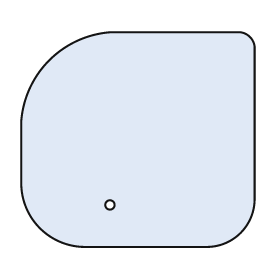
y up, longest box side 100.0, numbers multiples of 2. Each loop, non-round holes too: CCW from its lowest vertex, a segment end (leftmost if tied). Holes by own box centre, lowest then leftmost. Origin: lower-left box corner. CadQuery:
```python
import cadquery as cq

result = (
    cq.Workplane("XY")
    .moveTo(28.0, 0.0)
    .lineTo(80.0, 0.0)
    .threePointArc((94.0, 6.0), (100.0, 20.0))
    .lineTo(100.0, 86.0)
    .threePointArc((98.0, 90.0), (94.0, 92.0))
    .lineTo(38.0, 92.0)
    .threePointArc((12.0, 80.0), (0.0, 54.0))
    .lineTo(0.0, 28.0)
    .threePointArc((8.0, 8.0), (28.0, 0.0))
    .close()
    .moveTo(38.0, 18.0)
    .circle(2.0)
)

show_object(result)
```